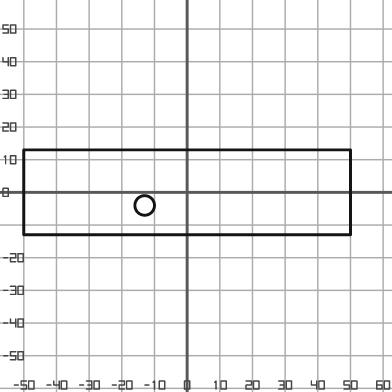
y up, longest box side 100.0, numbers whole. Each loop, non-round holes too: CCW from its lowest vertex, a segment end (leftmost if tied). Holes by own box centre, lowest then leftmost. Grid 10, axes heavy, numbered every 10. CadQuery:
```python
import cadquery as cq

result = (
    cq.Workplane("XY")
    .moveTo(-50.0, -13.0)
    .lineTo(50.0, -13.0)
    .lineTo(50.0, 13.0)
    .lineTo(-50.0, 13.0)
    .close()
    .moveTo(-13.0, -4.0)
    .circle(3.0)
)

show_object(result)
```